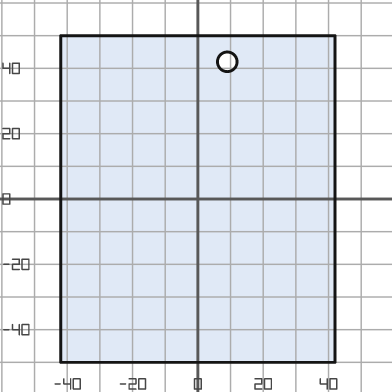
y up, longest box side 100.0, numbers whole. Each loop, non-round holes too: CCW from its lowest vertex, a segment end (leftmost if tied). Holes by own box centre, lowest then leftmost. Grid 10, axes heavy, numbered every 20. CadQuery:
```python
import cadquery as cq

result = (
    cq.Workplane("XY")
    .moveTo(-42.0, -50.0)
    .lineTo(42.0, -50.0)
    .lineTo(42.0, 50.0)
    .lineTo(-42.0, 50.0)
    .close()
    .moveTo(9.0, 42.0)
    .circle(3.0)
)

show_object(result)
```